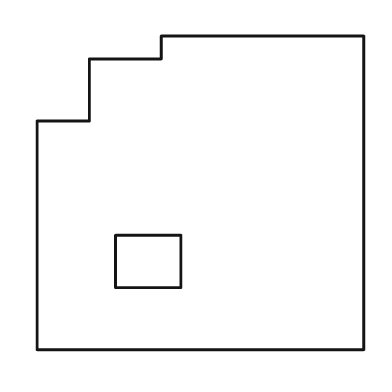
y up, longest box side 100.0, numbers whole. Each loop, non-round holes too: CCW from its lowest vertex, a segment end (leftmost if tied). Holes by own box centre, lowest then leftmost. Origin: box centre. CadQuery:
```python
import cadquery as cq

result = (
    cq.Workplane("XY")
    .moveTo(-50.0, -48.0)
    .lineTo(50.0, -48.0)
    .lineTo(50.0, 48.0)
    .lineTo(-12.0, 48.0)
    .lineTo(-12.0, 41.0)
    .lineTo(-34.0, 41.0)
    .lineTo(-34.0, 22.0)
    .lineTo(-50.0, 22.0)
    .close()
    .moveTo(-26.0, -29.0)
    .lineTo(-6.0, -29.0)
    .lineTo(-6.0, -13.0)
    .lineTo(-26.0, -13.0)
    .close()
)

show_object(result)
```